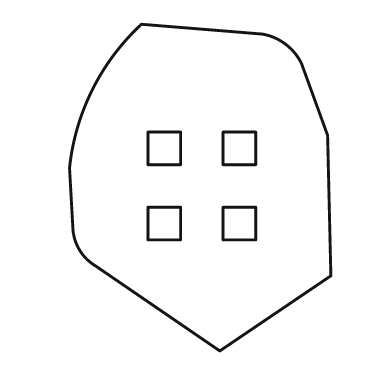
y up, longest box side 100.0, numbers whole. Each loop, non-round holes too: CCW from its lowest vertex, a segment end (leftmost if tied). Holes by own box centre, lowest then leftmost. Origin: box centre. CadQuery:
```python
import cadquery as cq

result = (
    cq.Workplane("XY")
    .moveTo(6.0, -50.0)
    .lineTo(40.0, -27.0)
    .lineTo(39.0, 16.0)
    .lineTo(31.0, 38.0)
    .threePointArc((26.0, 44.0), (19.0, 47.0))
    .lineTo(-18.0, 50.0)
    .threePointArc((-33.0, 30.0), (-40.0, 6.0))
    .lineTo(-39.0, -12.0)
    .threePointArc((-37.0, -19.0), (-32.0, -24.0))
    .close()
    .moveTo(-16.0, -16.0)
    .lineTo(-6.0, -16.0)
    .lineTo(-6.0, -6.0)
    .lineTo(-16.0, -6.0)
    .close()
    .moveTo(7.0, -16.0)
    .lineTo(17.0, -16.0)
    .lineTo(17.0, -6.0)
    .lineTo(7.0, -6.0)
    .close()
    .moveTo(-16.0, 7.0)
    .lineTo(-6.0, 7.0)
    .lineTo(-6.0, 17.0)
    .lineTo(-16.0, 17.0)
    .close()
    .moveTo(7.0, 7.0)
    .lineTo(17.0, 7.0)
    .lineTo(17.0, 17.0)
    .lineTo(7.0, 17.0)
    .close()
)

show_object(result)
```